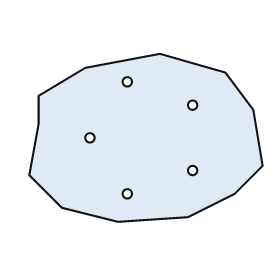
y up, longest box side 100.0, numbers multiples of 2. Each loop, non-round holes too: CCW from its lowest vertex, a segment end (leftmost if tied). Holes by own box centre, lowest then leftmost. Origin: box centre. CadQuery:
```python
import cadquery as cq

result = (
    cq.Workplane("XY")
    .moveTo(-12.0, -36.0)
    .lineTo(18.0, -34.0)
    .lineTo(38.0, -24.0)
    .lineTo(50.0, -12.0)
    .lineTo(46.0, 12.0)
    .lineTo(34.0, 28.0)
    .lineTo(6.0, 36.0)
    .lineTo(-26.0, 30.0)
    .lineTo(-46.0, 18.0)
    .lineTo(-46.0, 6.0)
    .lineTo(-50.0, -16.0)
    .lineTo(-36.0, -30.0)
    .close()
    .moveTo(-8.0, -24.0)
    .circle(2.0)
    .moveTo(20.0, -14.0)
    .circle(2.0)
    .moveTo(-24.0, 0.0)
    .circle(2.0)
    .moveTo(20.0, 14.0)
    .circle(2.0)
    .moveTo(-8.0, 24.0)
    .circle(2.0)
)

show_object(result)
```